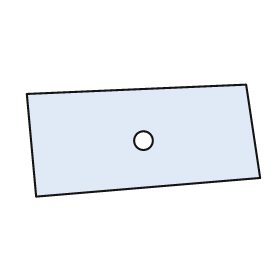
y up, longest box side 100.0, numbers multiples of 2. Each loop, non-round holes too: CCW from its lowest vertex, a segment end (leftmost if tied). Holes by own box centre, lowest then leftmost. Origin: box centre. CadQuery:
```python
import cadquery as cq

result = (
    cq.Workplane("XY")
    .moveTo(-46.0, -24.0)
    .lineTo(50.0, -16.0)
    .lineTo(44.0, 24.0)
    .lineTo(-50.0, 20.0)
    .close()
    .moveTo(0.0, 0.0)
    .circle(4.0)
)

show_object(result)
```